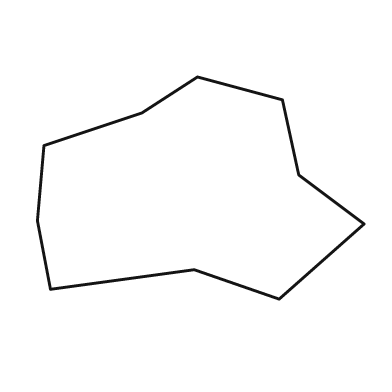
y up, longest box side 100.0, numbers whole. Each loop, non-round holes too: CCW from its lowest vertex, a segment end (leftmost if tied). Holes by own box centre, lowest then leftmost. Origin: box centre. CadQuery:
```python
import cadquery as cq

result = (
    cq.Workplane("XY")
    .moveTo(24.0, -34.0)
    .lineTo(50.0, -11.0)
    .lineTo(30.0, 4.0)
    .lineTo(25.0, 27.0)
    .lineTo(-1.0, 34.0)
    .lineTo(-18.0, 23.0)
    .lineTo(-48.0, 13.0)
    .lineTo(-50.0, -10.0)
    .lineTo(-46.0, -31.0)
    .lineTo(-2.0, -25.0)
    .close()
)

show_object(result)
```